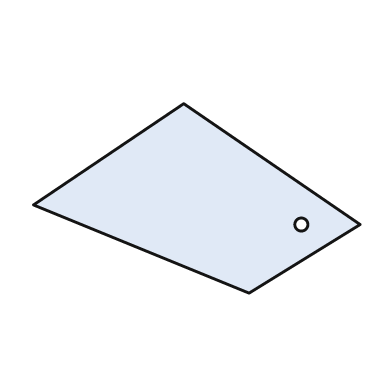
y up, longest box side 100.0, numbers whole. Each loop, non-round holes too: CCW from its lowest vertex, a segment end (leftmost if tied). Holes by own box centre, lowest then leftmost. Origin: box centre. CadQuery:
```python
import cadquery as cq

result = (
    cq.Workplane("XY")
    .moveTo(16.0, -29.0)
    .lineTo(50.0, -8.0)
    .lineTo(-4.0, 29.0)
    .lineTo(-50.0, -2.0)
    .close()
    .moveTo(32.0, -8.0)
    .circle(2.0)
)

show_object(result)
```